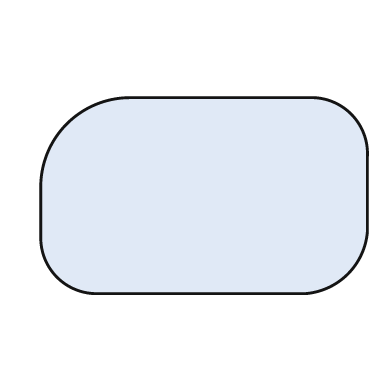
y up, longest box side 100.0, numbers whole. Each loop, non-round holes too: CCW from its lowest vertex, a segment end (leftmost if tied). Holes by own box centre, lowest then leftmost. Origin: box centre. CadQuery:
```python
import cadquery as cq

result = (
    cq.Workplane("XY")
    .moveTo(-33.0, -30.0)
    .lineTo(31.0, -30.0)
    .threePointArc((44.0, -24.0), (50.0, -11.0))
    .lineTo(50.0, 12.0)
    .threePointArc((45.0, 25.0), (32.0, 30.0))
    .lineTo(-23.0, 30.0)
    .threePointArc((-42.0, 22.0), (-50.0, 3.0))
    .lineTo(-50.0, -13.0)
    .threePointArc((-45.0, -25.0), (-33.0, -30.0))
    .close()
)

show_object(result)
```